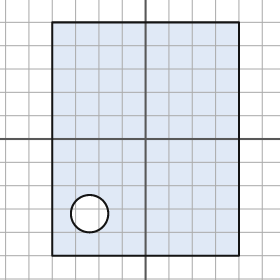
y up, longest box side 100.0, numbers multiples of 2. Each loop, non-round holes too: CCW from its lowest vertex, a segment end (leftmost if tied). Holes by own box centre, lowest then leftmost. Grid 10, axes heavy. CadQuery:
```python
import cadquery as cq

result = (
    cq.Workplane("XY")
    .moveTo(-40.0, -50.0)
    .lineTo(40.0, -50.0)
    .lineTo(40.0, 50.0)
    .lineTo(-40.0, 50.0)
    .close()
    .moveTo(-24.0, -32.0)
    .circle(8.0)
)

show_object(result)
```